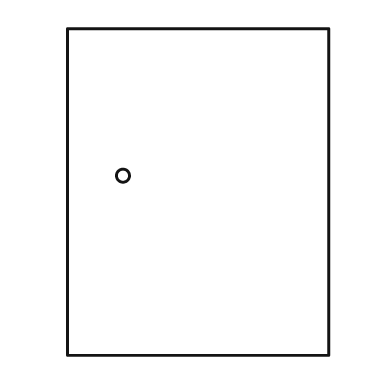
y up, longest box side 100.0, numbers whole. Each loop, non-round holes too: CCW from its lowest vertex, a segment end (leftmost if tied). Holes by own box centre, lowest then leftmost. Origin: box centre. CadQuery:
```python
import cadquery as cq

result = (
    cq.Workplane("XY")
    .moveTo(-40.0, -50.0)
    .lineTo(40.0, -50.0)
    .lineTo(40.0, 50.0)
    .lineTo(-40.0, 50.0)
    .close()
    .moveTo(-23.0, 5.0)
    .circle(2.0)
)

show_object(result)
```